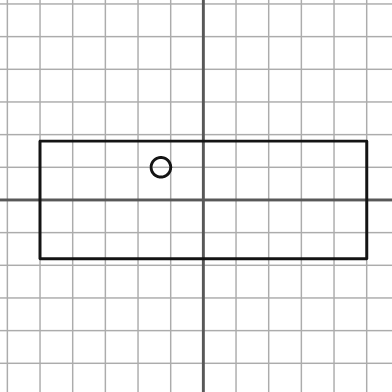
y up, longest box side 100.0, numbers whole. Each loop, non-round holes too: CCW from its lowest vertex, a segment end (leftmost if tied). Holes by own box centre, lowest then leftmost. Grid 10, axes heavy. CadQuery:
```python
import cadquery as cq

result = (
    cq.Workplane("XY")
    .moveTo(-50.0, -18.0)
    .lineTo(50.0, -18.0)
    .lineTo(50.0, 18.0)
    .lineTo(-50.0, 18.0)
    .close()
    .moveTo(-13.0, 10.0)
    .circle(3.0)
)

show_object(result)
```